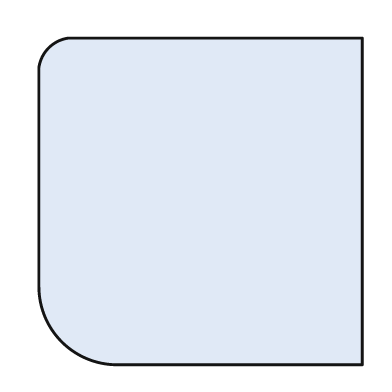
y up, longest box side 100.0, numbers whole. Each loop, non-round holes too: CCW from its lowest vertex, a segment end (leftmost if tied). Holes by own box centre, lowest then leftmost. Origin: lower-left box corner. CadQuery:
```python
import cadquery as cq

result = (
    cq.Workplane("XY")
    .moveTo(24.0, 0.0)
    .lineTo(99.0, 0.0)
    .lineTo(99.0, 100.0)
    .lineTo(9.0, 100.0)
    .threePointArc((3.0, 97.0), (0.0, 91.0))
    .lineTo(0.0, 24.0)
    .threePointArc((7.0, 7.0), (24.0, 0.0))
    .close()
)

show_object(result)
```